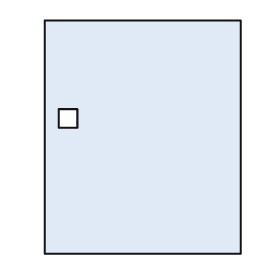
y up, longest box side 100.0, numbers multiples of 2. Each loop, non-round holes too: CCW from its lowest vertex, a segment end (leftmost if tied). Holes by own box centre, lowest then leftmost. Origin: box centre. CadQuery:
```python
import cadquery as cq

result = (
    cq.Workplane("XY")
    .moveTo(-42.0, -50.0)
    .lineTo(42.0, -50.0)
    .lineTo(42.0, 50.0)
    .lineTo(-42.0, 50.0)
    .close()
    .moveTo(-36.0, 4.0)
    .lineTo(-28.0, 4.0)
    .lineTo(-28.0, 12.0)
    .lineTo(-36.0, 12.0)
    .close()
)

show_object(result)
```